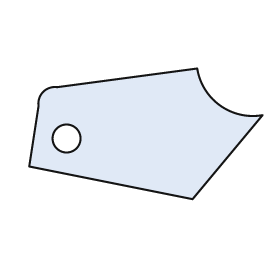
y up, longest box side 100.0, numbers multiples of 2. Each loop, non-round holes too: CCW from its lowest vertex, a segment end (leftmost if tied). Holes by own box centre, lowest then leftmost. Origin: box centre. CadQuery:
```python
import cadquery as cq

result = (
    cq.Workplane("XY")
    .moveTo(20.0, -28.0)
    .lineTo(50.0, 8.0)
    .threePointArc((32.0, 12.0), (22.0, 28.0))
    .lineTo(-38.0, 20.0)
    .threePointArc((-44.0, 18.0), (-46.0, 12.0))
    .lineTo(-50.0, -14.0)
    .close()
    .moveTo(-34.0, -2.0)
    .circle(6.0)
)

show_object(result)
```